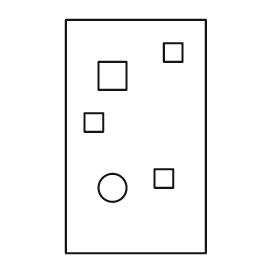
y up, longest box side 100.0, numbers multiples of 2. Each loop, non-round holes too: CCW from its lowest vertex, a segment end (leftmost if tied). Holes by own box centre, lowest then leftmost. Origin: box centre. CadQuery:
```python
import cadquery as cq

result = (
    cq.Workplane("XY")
    .moveTo(-30.0, -50.0)
    .lineTo(30.0, -50.0)
    .lineTo(30.0, 50.0)
    .lineTo(-30.0, 50.0)
    .close()
    .moveTo(-10.0, -22.0)
    .circle(6.0)
    .moveTo(8.0, -22.0)
    .lineTo(16.0, -22.0)
    .lineTo(16.0, -14.0)
    .lineTo(8.0, -14.0)
    .close()
    .moveTo(-22.0, 2.0)
    .lineTo(-14.0, 2.0)
    .lineTo(-14.0, 10.0)
    .lineTo(-22.0, 10.0)
    .close()
    .moveTo(-16.0, 20.0)
    .lineTo(-4.0, 20.0)
    .lineTo(-4.0, 32.0)
    .lineTo(-16.0, 32.0)
    .close()
    .moveTo(12.0, 32.0)
    .lineTo(20.0, 32.0)
    .lineTo(20.0, 40.0)
    .lineTo(12.0, 40.0)
    .close()
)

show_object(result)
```